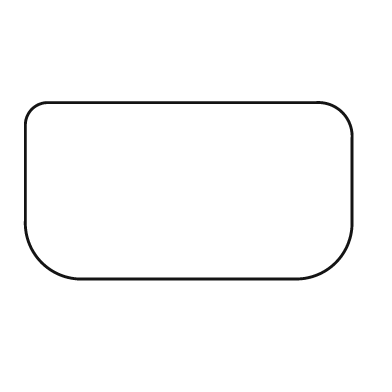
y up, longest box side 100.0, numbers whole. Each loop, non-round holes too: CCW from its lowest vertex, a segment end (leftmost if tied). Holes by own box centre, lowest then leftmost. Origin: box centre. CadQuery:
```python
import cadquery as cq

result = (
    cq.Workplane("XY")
    .moveTo(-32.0, -27.0)
    .lineTo(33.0, -27.0)
    .threePointArc((45.0, -22.0), (50.0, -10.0))
    .lineTo(50.0, 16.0)
    .threePointArc((47.0, 24.0), (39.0, 27.0))
    .lineTo(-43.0, 27.0)
    .threePointArc((-48.0, 25.0), (-50.0, 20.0))
    .lineTo(-50.0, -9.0)
    .threePointArc((-45.0, -22.0), (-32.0, -27.0))
    .close()
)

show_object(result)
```